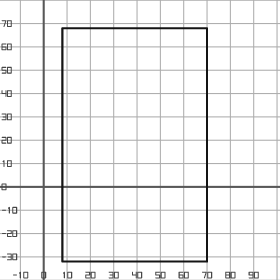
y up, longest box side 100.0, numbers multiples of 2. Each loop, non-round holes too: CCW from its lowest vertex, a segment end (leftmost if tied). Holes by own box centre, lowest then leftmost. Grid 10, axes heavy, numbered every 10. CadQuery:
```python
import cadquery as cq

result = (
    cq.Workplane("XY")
    .moveTo(8.0, -32.0)
    .lineTo(70.0, -32.0)
    .lineTo(70.0, 68.0)
    .lineTo(8.0, 68.0)
    .close()
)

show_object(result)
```